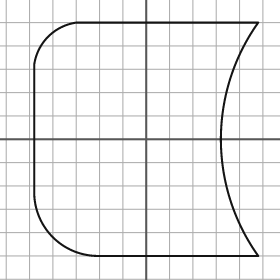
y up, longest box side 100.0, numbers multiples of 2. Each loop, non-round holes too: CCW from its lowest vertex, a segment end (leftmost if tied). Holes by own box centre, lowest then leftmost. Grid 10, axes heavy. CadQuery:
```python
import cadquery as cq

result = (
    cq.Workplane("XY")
    .moveTo(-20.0, -50.0)
    .lineTo(48.0, -50.0)
    .threePointArc((32.0, 0.0), (48.0, 50.0))
    .lineTo(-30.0, 50.0)
    .threePointArc((-42.0, 44.0), (-48.0, 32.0))
    .lineTo(-48.0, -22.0)
    .threePointArc((-40.0, -42.0), (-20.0, -50.0))
    .close()
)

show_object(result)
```